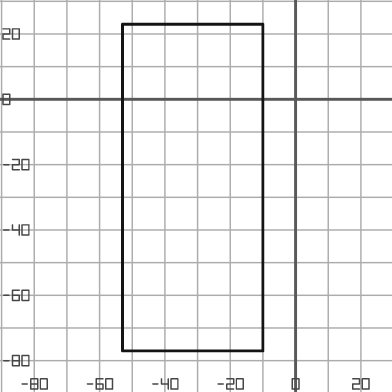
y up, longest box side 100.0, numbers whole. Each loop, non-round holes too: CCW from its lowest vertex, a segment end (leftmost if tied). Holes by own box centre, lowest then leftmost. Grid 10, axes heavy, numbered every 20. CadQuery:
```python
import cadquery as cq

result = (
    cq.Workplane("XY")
    .moveTo(-53.0, -77.0)
    .lineTo(-10.0, -77.0)
    .lineTo(-10.0, 23.0)
    .lineTo(-53.0, 23.0)
    .close()
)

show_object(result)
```